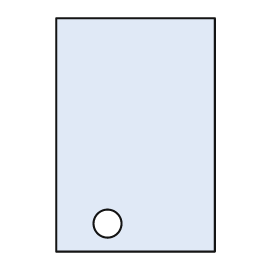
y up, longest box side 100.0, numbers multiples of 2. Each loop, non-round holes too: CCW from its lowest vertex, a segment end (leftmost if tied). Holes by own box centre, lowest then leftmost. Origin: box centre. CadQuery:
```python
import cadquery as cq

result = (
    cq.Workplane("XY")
    .moveTo(-34.0, -50.0)
    .lineTo(34.0, -50.0)
    .lineTo(34.0, 50.0)
    .lineTo(-34.0, 50.0)
    .close()
    .moveTo(-12.0, -38.0)
    .circle(6.0)
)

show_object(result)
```